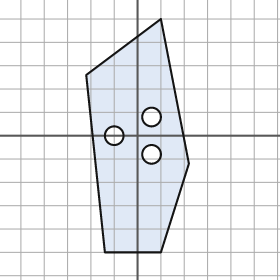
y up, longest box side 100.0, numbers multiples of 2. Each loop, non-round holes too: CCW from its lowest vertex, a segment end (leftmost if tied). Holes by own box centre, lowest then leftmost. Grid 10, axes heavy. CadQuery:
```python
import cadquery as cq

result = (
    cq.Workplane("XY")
    .moveTo(-14.0, -50.0)
    .lineTo(10.0, -50.0)
    .lineTo(22.0, -12.0)
    .lineTo(10.0, 50.0)
    .lineTo(-22.0, 26.0)
    .close()
    .moveTo(6.0, -8.0)
    .circle(4.0)
    .moveTo(-10.0, 0.0)
    .circle(4.0)
    .moveTo(6.0, 8.0)
    .circle(4.0)
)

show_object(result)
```